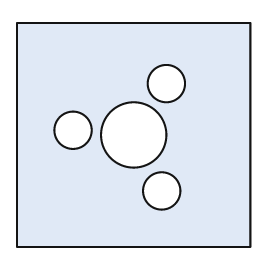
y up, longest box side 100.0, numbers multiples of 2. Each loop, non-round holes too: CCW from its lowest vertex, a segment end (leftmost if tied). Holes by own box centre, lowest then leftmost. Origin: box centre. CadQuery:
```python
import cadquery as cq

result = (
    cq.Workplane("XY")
    .moveTo(-50.0, -48.0)
    .lineTo(50.0, -48.0)
    .lineTo(50.0, 48.0)
    .lineTo(-50.0, 48.0)
    .close()
    .moveTo(12.0, -24.0)
    .circle(8.0)
    .moveTo(0.0, 0.0)
    .circle(14.0)
    .moveTo(-26.0, 2.0)
    .circle(8.0)
    .moveTo(14.0, 22.0)
    .circle(8.0)
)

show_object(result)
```